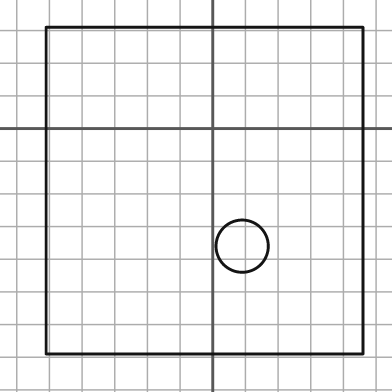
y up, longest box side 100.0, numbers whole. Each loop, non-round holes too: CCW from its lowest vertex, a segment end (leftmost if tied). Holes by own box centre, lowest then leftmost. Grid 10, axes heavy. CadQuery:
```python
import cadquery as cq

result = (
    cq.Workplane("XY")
    .moveTo(-51.0, -69.0)
    .lineTo(46.0, -69.0)
    .lineTo(46.0, 31.0)
    .lineTo(-51.0, 31.0)
    .close()
    .moveTo(9.0, -36.0)
    .circle(8.0)
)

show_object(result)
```